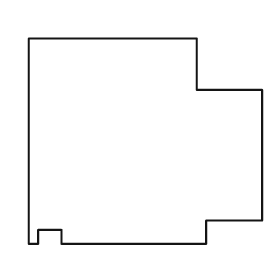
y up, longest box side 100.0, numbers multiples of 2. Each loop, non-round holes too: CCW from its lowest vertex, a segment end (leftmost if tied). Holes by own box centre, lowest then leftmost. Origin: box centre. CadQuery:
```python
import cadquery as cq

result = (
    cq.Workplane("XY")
    .moveTo(-50.0, -44.0)
    .lineTo(-46.0, -44.0)
    .lineTo(-46.0, -38.0)
    .lineTo(-36.0, -38.0)
    .lineTo(-36.0, -44.0)
    .lineTo(26.0, -44.0)
    .lineTo(26.0, -34.0)
    .lineTo(50.0, -34.0)
    .lineTo(50.0, 22.0)
    .lineTo(22.0, 22.0)
    .lineTo(22.0, 44.0)
    .lineTo(-50.0, 44.0)
    .close()
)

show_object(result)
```